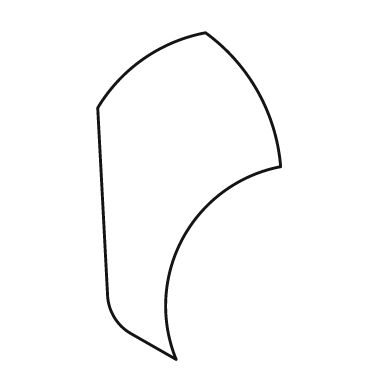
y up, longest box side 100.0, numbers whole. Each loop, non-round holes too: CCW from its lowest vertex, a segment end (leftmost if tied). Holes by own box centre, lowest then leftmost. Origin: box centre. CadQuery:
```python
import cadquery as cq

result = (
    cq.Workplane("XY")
    .moveTo(-4.0, -50.0)
    .threePointArc((-2.0, -13.0), (28.0, 9.0))
    .threePointArc((21.0, 32.0), (5.0, 50.0))
    .threePointArc((-14.0, 42.0), (-28.0, 27.0))
    .lineTo(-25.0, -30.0)
    .threePointArc((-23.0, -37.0), (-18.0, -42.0))
    .close()
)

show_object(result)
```